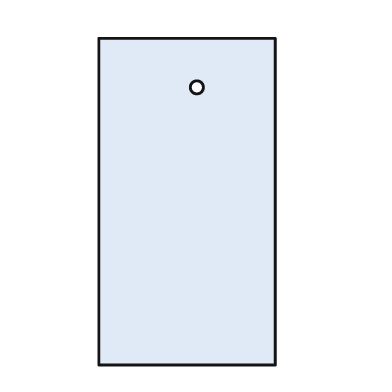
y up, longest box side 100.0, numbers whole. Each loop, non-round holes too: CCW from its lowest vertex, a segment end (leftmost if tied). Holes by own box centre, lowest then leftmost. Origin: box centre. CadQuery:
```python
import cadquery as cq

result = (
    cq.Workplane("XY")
    .moveTo(-27.0, -50.0)
    .lineTo(27.0, -50.0)
    .lineTo(27.0, 50.0)
    .lineTo(-27.0, 50.0)
    .close()
    .moveTo(3.0, 35.0)
    .circle(2.0)
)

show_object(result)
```